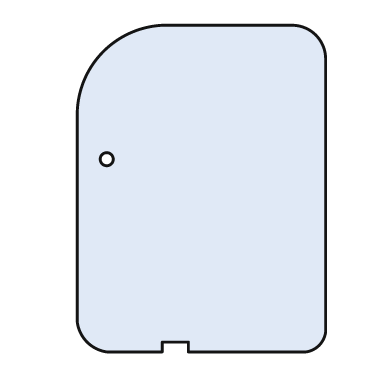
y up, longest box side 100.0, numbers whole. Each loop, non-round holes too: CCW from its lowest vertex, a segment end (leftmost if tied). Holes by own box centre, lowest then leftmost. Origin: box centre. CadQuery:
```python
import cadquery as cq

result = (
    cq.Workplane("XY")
    .moveTo(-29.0, -50.0)
    .lineTo(-12.0, -50.0)
    .lineTo(-12.0, -47.0)
    .lineTo(-4.0, -47.0)
    .lineTo(-4.0, -50.0)
    .lineTo(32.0, -50.0)
    .threePointArc((36.0, -48.0), (38.0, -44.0))
    .lineTo(38.0, 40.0)
    .threePointArc((35.0, 47.0), (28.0, 50.0))
    .lineTo(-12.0, 50.0)
    .threePointArc((-30.0, 42.0), (-38.0, 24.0))
    .lineTo(-38.0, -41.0)
    .threePointArc((-35.0, -47.0), (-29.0, -50.0))
    .close()
    .moveTo(-29.0, 9.0)
    .circle(2.0)
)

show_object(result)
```